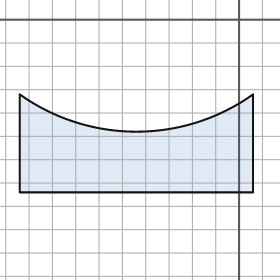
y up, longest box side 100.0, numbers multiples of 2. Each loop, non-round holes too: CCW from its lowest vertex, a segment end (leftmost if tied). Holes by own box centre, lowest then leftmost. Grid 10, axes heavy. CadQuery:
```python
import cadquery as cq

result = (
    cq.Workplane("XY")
    .moveTo(-94.0, -74.0)
    .lineTo(6.0, -74.0)
    .lineTo(6.0, -32.0)
    .threePointArc((-44.0, -48.0), (-94.0, -32.0))
    .close()
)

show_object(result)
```